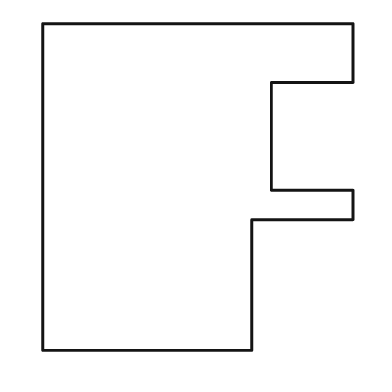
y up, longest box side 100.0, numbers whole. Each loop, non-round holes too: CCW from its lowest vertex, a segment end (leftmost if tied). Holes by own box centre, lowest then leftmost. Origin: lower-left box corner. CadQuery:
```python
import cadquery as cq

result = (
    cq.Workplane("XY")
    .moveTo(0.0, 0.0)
    .lineTo(64.0, 0.0)
    .lineTo(64.0, 40.0)
    .lineTo(95.0, 40.0)
    .lineTo(95.0, 49.0)
    .lineTo(70.0, 49.0)
    .lineTo(70.0, 82.0)
    .lineTo(95.0, 82.0)
    .lineTo(95.0, 100.0)
    .lineTo(0.0, 100.0)
    .close()
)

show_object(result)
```